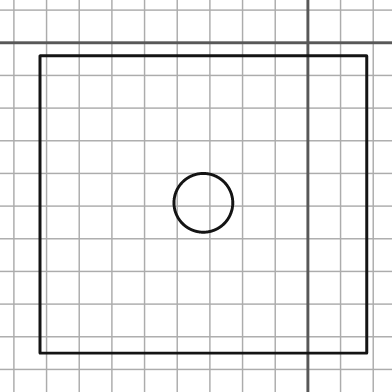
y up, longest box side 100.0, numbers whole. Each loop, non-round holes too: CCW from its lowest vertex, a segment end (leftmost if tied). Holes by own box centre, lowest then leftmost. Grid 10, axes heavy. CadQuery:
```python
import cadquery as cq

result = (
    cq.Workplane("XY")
    .moveTo(-82.0, -95.0)
    .lineTo(18.0, -95.0)
    .lineTo(18.0, -4.0)
    .lineTo(-82.0, -4.0)
    .close()
    .moveTo(-32.0, -49.0)
    .circle(9.0)
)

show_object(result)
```